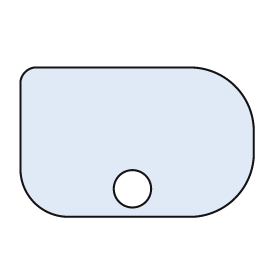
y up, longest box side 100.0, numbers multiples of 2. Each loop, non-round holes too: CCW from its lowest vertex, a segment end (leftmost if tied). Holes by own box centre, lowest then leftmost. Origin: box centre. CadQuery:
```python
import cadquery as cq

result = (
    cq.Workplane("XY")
    .moveTo(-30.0, -32.0)
    .lineTo(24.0, -32.0)
    .threePointArc((42.0, -24.0), (50.0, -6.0))
    .lineTo(50.0, 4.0)
    .threePointArc((42.0, 24.0), (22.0, 32.0))
    .lineTo(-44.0, 32.0)
    .threePointArc((-48.0, 30.0), (-50.0, 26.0))
    .lineTo(-50.0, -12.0)
    .threePointArc((-44.0, -26.0), (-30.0, -32.0))
    .close()
    .moveTo(-2.0, -20.0)
    .circle(8.0)
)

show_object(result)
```